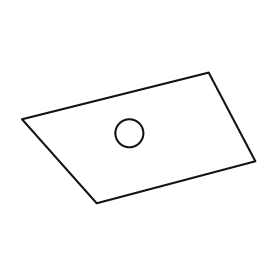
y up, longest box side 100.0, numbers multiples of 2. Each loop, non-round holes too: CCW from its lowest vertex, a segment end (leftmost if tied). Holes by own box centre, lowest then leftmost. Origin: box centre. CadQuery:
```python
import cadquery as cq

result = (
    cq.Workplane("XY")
    .moveTo(-18.0, -28.0)
    .lineTo(50.0, -10.0)
    .lineTo(30.0, 28.0)
    .lineTo(-50.0, 8.0)
    .close()
    .moveTo(-4.0, 2.0)
    .circle(6.0)
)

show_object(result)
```